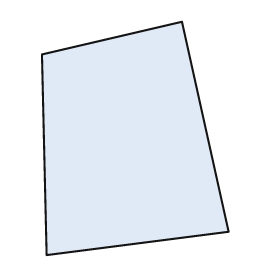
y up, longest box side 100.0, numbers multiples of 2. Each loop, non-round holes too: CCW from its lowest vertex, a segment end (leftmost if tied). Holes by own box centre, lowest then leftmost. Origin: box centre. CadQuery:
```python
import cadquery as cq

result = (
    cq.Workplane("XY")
    .moveTo(-38.0, -50.0)
    .lineTo(40.0, -40.0)
    .lineTo(20.0, 50.0)
    .lineTo(-40.0, 36.0)
    .close()
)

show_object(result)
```